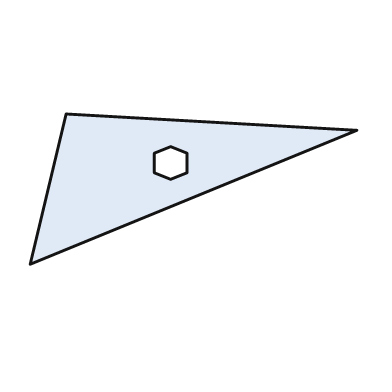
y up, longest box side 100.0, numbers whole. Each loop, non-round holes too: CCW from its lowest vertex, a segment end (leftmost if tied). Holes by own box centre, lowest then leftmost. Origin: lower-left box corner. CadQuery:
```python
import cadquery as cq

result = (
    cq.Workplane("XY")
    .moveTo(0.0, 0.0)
    .lineTo(100.0, 41.0)
    .lineTo(11.0, 46.0)
    .close()
    .moveTo(43.0, 26.0)
    .lineTo(48.0, 28.0)
    .lineTo(48.0, 34.0)
    .lineTo(43.0, 36.0)
    .lineTo(38.0, 34.0)
    .lineTo(38.0, 28.0)
    .close()
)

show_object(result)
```